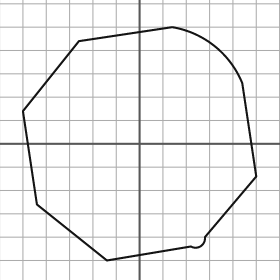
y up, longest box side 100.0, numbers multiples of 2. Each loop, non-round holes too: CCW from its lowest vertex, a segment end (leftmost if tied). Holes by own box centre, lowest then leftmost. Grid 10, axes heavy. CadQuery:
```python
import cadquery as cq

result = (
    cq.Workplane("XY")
    .moveTo(-14.0, -50.0)
    .lineTo(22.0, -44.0)
    .threePointArc((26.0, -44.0), (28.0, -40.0))
    .lineTo(50.0, -14.0)
    .lineTo(44.0, 26.0)
    .threePointArc((32.0, 42.0), (14.0, 50.0))
    .lineTo(-26.0, 44.0)
    .lineTo(-50.0, 14.0)
    .lineTo(-44.0, -26.0)
    .close()
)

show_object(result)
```